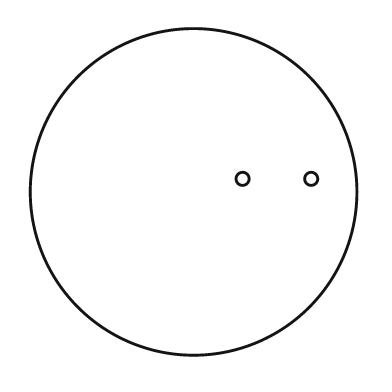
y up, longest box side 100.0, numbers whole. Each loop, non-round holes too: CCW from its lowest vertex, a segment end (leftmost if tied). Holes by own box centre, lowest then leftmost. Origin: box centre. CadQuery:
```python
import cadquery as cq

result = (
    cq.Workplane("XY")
    .moveTo(0.0, 0.0)
    .circle(50.0)
    .moveTo(15.0, 4.0)
    .circle(2.0)
    .moveTo(36.0, 4.0)
    .circle(2.0)
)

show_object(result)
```